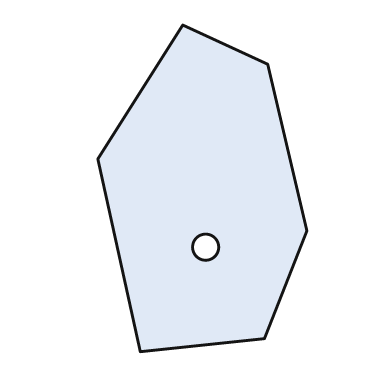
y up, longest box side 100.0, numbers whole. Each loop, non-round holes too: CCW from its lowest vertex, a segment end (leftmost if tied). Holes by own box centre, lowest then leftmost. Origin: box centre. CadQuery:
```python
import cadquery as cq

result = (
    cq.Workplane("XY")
    .moveTo(-19.0, -50.0)
    .lineTo(19.0, -46.0)
    .lineTo(32.0, -13.0)
    .lineTo(20.0, 38.0)
    .lineTo(-6.0, 50.0)
    .lineTo(-32.0, 9.0)
    .close()
    .moveTo(1.0, -18.0)
    .circle(4.0)
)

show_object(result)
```